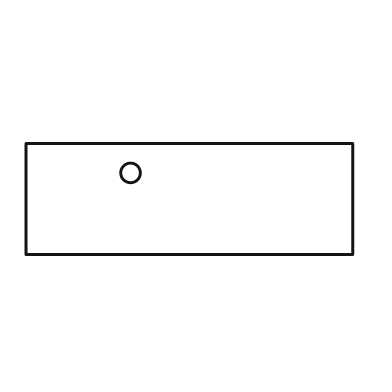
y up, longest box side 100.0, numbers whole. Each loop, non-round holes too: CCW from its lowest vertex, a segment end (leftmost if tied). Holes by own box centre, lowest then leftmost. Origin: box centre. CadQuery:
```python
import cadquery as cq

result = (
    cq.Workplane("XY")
    .moveTo(-50.0, -17.0)
    .lineTo(50.0, -17.0)
    .lineTo(50.0, 17.0)
    .lineTo(-50.0, 17.0)
    .close()
    .moveTo(-18.0, 8.0)
    .circle(3.0)
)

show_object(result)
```